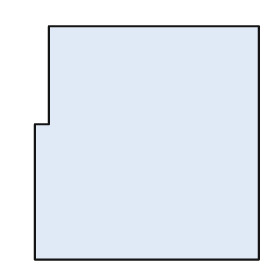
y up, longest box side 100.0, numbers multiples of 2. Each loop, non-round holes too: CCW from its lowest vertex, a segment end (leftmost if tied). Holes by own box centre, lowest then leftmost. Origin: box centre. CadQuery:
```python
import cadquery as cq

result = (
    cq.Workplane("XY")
    .moveTo(-48.0, -50.0)
    .lineTo(48.0, -50.0)
    .lineTo(48.0, 50.0)
    .lineTo(-42.0, 50.0)
    .lineTo(-42.0, 8.0)
    .lineTo(-48.0, 8.0)
    .close()
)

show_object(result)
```